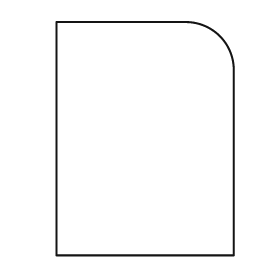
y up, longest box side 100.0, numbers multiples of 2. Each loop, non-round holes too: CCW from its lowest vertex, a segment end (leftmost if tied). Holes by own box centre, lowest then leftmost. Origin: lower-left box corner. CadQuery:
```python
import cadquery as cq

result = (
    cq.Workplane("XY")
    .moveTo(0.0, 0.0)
    .lineTo(76.0, 0.0)
    .lineTo(76.0, 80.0)
    .threePointArc((70.0, 94.0), (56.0, 100.0))
    .lineTo(0.0, 100.0)
    .close()
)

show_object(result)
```